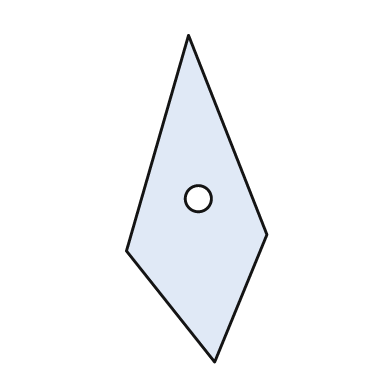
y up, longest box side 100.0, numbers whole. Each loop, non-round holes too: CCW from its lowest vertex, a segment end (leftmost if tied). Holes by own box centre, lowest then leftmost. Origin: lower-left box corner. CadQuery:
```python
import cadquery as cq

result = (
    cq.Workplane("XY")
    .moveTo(27.0, 0.0)
    .lineTo(43.0, 39.0)
    .lineTo(19.0, 100.0)
    .lineTo(0.0, 34.0)
    .close()
    .moveTo(22.0, 50.0)
    .circle(4.0)
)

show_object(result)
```